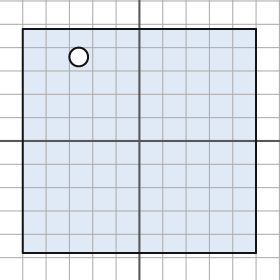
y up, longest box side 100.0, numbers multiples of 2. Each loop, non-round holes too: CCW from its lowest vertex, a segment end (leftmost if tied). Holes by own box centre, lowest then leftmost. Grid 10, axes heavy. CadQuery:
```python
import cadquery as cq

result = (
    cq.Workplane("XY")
    .moveTo(-50.0, -48.0)
    .lineTo(50.0, -48.0)
    .lineTo(50.0, 48.0)
    .lineTo(-50.0, 48.0)
    .close()
    .moveTo(-26.0, 36.0)
    .circle(4.0)
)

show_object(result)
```